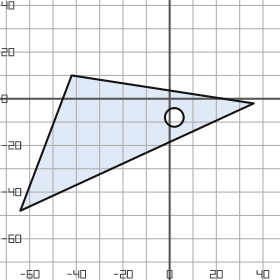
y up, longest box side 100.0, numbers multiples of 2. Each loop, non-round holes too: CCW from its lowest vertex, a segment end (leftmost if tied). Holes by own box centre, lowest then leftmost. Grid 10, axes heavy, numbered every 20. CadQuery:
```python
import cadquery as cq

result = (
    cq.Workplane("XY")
    .moveTo(-64.0, -48.0)
    .lineTo(36.0, -2.0)
    .lineTo(-42.0, 10.0)
    .close()
    .moveTo(2.0, -8.0)
    .circle(4.0)
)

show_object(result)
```